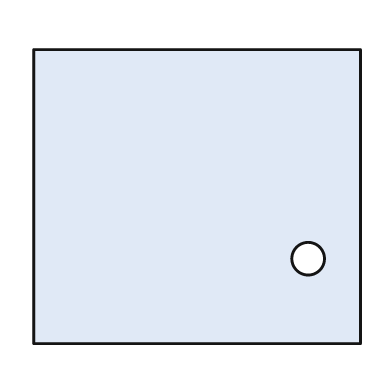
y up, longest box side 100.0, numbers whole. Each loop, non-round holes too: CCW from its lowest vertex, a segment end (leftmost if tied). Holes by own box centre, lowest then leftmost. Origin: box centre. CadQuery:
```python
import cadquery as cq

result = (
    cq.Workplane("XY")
    .moveTo(-50.0, -45.0)
    .lineTo(50.0, -45.0)
    .lineTo(50.0, 45.0)
    .lineTo(-50.0, 45.0)
    .close()
    .moveTo(34.0, -19.0)
    .circle(5.0)
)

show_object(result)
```